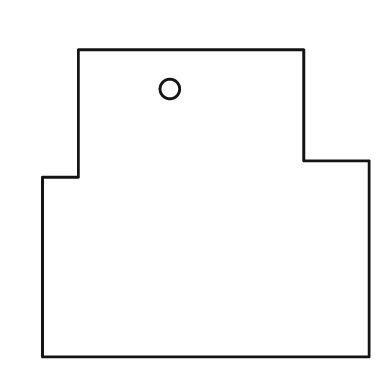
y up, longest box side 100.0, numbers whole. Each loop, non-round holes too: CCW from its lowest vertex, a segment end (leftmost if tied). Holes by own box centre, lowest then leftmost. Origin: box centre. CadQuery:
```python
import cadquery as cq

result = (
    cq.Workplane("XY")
    .moveTo(-50.0, -47.0)
    .lineTo(50.0, -47.0)
    .lineTo(50.0, 13.0)
    .lineTo(30.0, 13.0)
    .lineTo(30.0, 47.0)
    .lineTo(-39.0, 47.0)
    .lineTo(-39.0, 8.0)
    .lineTo(-50.0, 8.0)
    .close()
    .moveTo(-11.0, 35.0)
    .circle(3.0)
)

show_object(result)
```